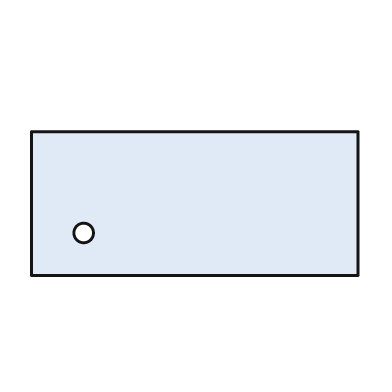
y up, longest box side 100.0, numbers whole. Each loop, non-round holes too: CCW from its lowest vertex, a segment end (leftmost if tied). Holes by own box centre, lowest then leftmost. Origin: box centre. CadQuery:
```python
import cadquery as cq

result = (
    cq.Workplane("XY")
    .moveTo(-50.0, -22.0)
    .lineTo(50.0, -22.0)
    .lineTo(50.0, 22.0)
    .lineTo(-50.0, 22.0)
    .close()
    .moveTo(-34.0, -9.0)
    .circle(3.0)
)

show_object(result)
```